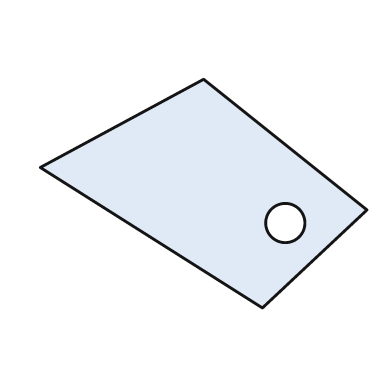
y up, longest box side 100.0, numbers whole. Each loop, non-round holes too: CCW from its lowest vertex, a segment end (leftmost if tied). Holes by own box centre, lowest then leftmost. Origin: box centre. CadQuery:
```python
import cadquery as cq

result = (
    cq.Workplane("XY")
    .moveTo(18.0, -35.0)
    .lineTo(50.0, -5.0)
    .lineTo(0.0, 35.0)
    .lineTo(-50.0, 8.0)
    .close()
    .moveTo(25.0, -9.0)
    .circle(6.0)
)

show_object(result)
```